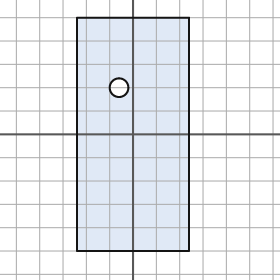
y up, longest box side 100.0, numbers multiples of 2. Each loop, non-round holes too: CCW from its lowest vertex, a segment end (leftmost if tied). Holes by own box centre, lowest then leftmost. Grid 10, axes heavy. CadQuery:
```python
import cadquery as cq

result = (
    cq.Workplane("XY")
    .moveTo(-24.0, -50.0)
    .lineTo(24.0, -50.0)
    .lineTo(24.0, 50.0)
    .lineTo(-24.0, 50.0)
    .close()
    .moveTo(-6.0, 20.0)
    .circle(4.0)
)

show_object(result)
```